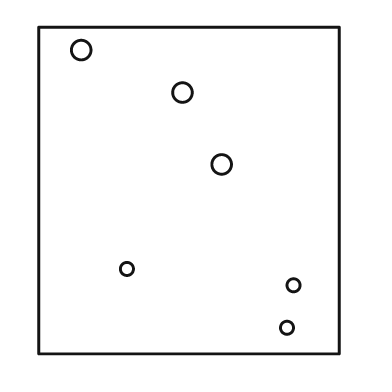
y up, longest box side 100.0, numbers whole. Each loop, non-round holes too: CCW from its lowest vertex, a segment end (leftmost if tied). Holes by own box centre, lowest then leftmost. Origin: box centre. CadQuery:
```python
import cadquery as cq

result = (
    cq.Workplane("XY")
    .moveTo(-46.0, -50.0)
    .lineTo(46.0, -50.0)
    .lineTo(46.0, 50.0)
    .lineTo(-46.0, 50.0)
    .close()
    .moveTo(30.0, -42.0)
    .circle(2.0)
    .moveTo(32.0, -29.0)
    .circle(2.0)
    .moveTo(-19.0, -24.0)
    .circle(2.0)
    .moveTo(10.0, 8.0)
    .circle(3.0)
    .moveTo(-2.0, 30.0)
    .circle(3.0)
    .moveTo(-33.0, 43.0)
    .circle(3.0)
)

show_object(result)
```